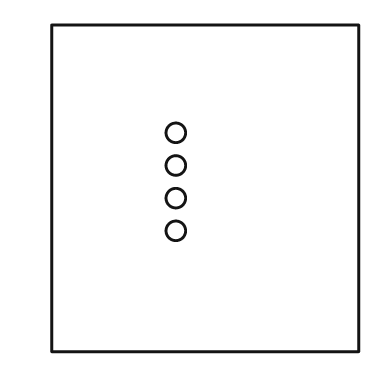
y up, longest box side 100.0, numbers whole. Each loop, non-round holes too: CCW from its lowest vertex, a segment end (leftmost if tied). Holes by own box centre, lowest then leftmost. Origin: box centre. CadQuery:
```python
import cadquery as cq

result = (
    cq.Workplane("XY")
    .moveTo(-47.0, -50.0)
    .lineTo(47.0, -50.0)
    .lineTo(47.0, 50.0)
    .lineTo(-47.0, 50.0)
    .close()
    .moveTo(-9.0, -13.0)
    .circle(3.0)
    .moveTo(-9.0, -3.0)
    .circle(3.0)
    .moveTo(-9.0, 7.0)
    .circle(3.0)
    .moveTo(-9.0, 17.0)
    .circle(3.0)
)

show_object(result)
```